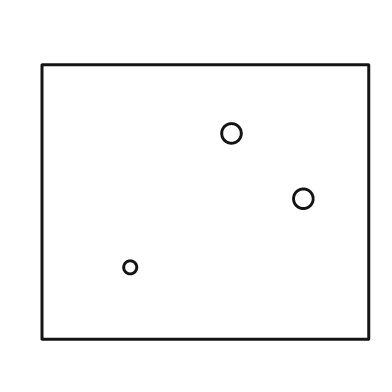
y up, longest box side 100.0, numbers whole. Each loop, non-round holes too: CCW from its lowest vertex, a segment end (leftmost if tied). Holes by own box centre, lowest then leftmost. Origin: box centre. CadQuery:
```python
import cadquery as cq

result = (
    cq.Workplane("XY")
    .moveTo(-50.0, -42.0)
    .lineTo(50.0, -42.0)
    .lineTo(50.0, 42.0)
    .lineTo(-50.0, 42.0)
    .close()
    .moveTo(-23.0, -20.0)
    .circle(2.0)
    .moveTo(30.0, 1.0)
    .circle(3.0)
    .moveTo(8.0, 21.0)
    .circle(3.0)
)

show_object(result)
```